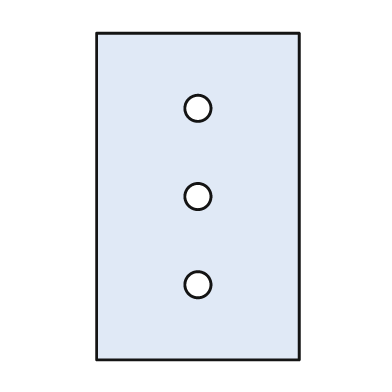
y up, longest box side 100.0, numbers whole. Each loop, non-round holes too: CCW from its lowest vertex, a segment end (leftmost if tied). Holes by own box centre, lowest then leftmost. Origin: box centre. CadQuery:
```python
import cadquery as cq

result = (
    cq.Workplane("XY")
    .moveTo(-31.0, -50.0)
    .lineTo(31.0, -50.0)
    .lineTo(31.0, 50.0)
    .lineTo(-31.0, 50.0)
    .close()
    .moveTo(0.0, -27.0)
    .circle(4.0)
    .moveTo(0.0, 0.0)
    .circle(4.0)
    .moveTo(0.0, 27.0)
    .circle(4.0)
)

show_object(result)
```